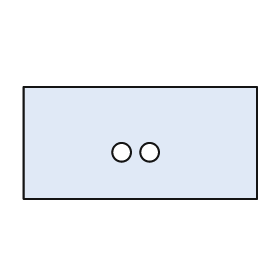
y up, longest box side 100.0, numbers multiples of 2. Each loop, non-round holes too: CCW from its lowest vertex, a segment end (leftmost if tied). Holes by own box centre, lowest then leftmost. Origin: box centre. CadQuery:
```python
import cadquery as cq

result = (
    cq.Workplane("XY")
    .moveTo(-50.0, -24.0)
    .lineTo(50.0, -24.0)
    .lineTo(50.0, 24.0)
    .lineTo(-50.0, 24.0)
    .close()
    .moveTo(-8.0, -4.0)
    .circle(4.0)
    .moveTo(4.0, -4.0)
    .circle(4.0)
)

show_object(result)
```